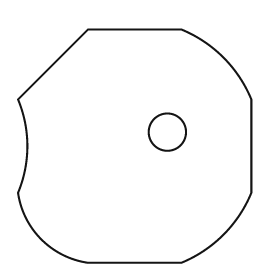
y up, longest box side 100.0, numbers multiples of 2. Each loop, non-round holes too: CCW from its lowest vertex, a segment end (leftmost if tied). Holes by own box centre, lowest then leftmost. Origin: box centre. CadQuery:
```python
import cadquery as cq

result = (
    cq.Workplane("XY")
    .moveTo(-20.0, -50.0)
    .lineTo(20.0, -50.0)
    .threePointArc((38.0, -38.0), (50.0, -20.0))
    .lineTo(50.0, 20.0)
    .threePointArc((38.0, 38.0), (20.0, 50.0))
    .lineTo(-20.0, 50.0)
    .lineTo(-50.0, 20.0)
    .threePointArc((-46.0, 0.0), (-50.0, -20.0))
    .threePointArc((-40.0, -40.0), (-20.0, -50.0))
    .close()
    .moveTo(14.0, 6.0)
    .circle(8.0)
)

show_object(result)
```